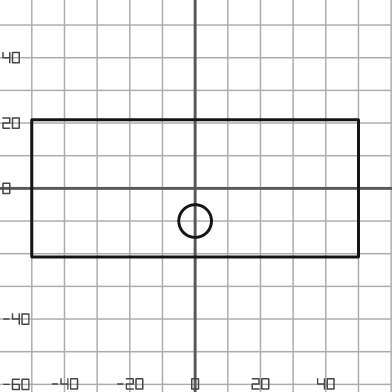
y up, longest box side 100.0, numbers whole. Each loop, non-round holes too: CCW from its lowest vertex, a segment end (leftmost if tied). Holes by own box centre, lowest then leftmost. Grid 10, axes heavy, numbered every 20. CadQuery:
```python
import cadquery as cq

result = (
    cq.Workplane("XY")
    .moveTo(-50.0, -21.0)
    .lineTo(50.0, -21.0)
    .lineTo(50.0, 21.0)
    .lineTo(-50.0, 21.0)
    .close()
    .moveTo(0.0, -10.0)
    .circle(5.0)
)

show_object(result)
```